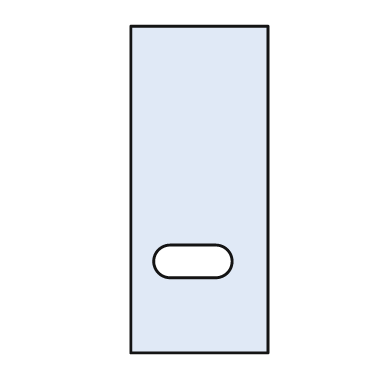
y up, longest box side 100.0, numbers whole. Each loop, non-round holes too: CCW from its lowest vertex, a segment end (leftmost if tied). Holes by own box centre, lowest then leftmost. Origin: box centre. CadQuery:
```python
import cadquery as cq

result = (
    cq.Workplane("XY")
    .moveTo(-21.0, -50.0)
    .lineTo(21.0, -50.0)
    .lineTo(21.0, 50.0)
    .lineTo(-21.0, 50.0)
    .close()
    .moveTo(-9.0, -27.0)
    .lineTo(5.0, -27.0)
    .threePointArc((10.0, -22.0), (5.0, -17.0))
    .lineTo(-9.0, -17.0)
    .threePointArc((-14.0, -22.0), (-9.0, -27.0))
    .close()
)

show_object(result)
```